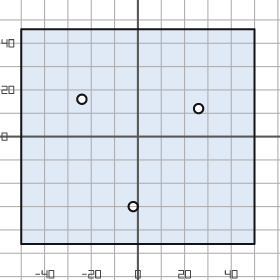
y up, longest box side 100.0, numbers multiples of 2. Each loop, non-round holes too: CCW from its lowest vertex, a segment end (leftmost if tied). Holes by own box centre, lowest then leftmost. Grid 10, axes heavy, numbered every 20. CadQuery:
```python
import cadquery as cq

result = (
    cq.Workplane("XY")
    .moveTo(-50.0, -46.0)
    .lineTo(50.0, -46.0)
    .lineTo(50.0, 46.0)
    .lineTo(-50.0, 46.0)
    .close()
    .moveTo(-2.0, -30.0)
    .circle(2.0)
    .moveTo(26.0, 12.0)
    .circle(2.0)
    .moveTo(-24.0, 16.0)
    .circle(2.0)
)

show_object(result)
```